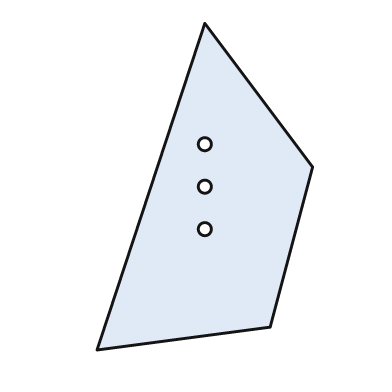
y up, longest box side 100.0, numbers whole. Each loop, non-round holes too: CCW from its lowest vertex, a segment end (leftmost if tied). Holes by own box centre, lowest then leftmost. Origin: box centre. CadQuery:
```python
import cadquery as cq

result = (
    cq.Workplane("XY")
    .moveTo(-33.0, -50.0)
    .lineTo(20.0, -43.0)
    .lineTo(33.0, 6.0)
    .lineTo(0.0, 50.0)
    .close()
    .moveTo(0.0, -13.0)
    .circle(2.0)
    .moveTo(0.0, 0.0)
    .circle(2.0)
    .moveTo(0.0, 13.0)
    .circle(2.0)
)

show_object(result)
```